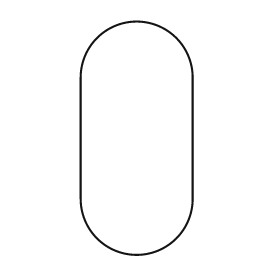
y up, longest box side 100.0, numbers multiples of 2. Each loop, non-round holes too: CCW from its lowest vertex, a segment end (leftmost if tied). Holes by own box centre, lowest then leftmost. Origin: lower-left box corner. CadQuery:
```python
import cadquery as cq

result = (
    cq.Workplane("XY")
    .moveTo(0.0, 24.0)
    .threePointArc((24.0, 0.0), (48.0, 24.0))
    .lineTo(48.0, 76.0)
    .threePointArc((24.0, 100.0), (0.0, 76.0))
    .close()
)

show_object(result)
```